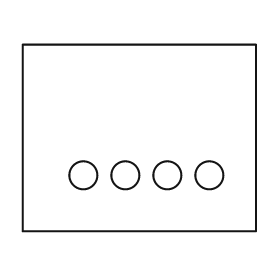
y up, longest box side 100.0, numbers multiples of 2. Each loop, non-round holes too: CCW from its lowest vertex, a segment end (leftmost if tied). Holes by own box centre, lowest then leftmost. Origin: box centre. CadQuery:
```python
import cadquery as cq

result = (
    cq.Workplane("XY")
    .moveTo(-50.0, -40.0)
    .lineTo(50.0, -40.0)
    .lineTo(50.0, 40.0)
    .lineTo(-50.0, 40.0)
    .close()
    .moveTo(-24.0, -16.0)
    .circle(6.0)
    .moveTo(-6.0, -16.0)
    .circle(6.0)
    .moveTo(12.0, -16.0)
    .circle(6.0)
    .moveTo(30.0, -16.0)
    .circle(6.0)
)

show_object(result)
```